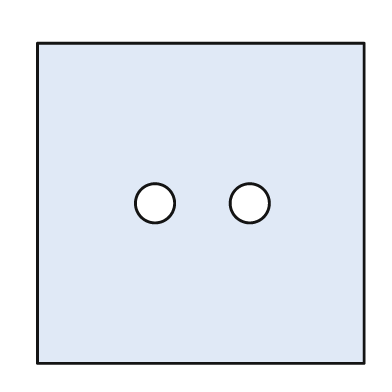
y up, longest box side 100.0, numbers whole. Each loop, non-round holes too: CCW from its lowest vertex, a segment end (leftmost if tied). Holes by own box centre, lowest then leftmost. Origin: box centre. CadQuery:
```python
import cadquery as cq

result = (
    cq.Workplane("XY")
    .moveTo(-50.0, -49.0)
    .lineTo(50.0, -49.0)
    .lineTo(50.0, 49.0)
    .lineTo(-50.0, 49.0)
    .close()
    .moveTo(-14.0, 0.0)
    .circle(6.0)
    .moveTo(15.0, 0.0)
    .circle(6.0)
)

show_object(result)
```